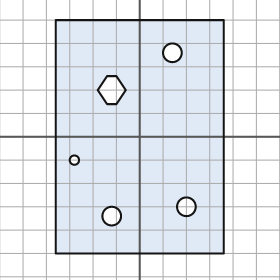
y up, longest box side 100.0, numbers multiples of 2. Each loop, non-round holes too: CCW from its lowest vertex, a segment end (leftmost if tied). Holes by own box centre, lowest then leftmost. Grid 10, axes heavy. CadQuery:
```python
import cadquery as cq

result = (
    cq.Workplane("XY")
    .moveTo(-36.0, -50.0)
    .lineTo(36.0, -50.0)
    .lineTo(36.0, 50.0)
    .lineTo(-36.0, 50.0)
    .close()
    .moveTo(-12.0, -34.0)
    .circle(4.0)
    .moveTo(20.0, -30.0)
    .circle(4.0)
    .moveTo(-28.0, -10.0)
    .circle(2.0)
    .moveTo(-14.0, 14.0)
    .lineTo(-10.0, 14.0)
    .lineTo(-6.0, 20.0)
    .lineTo(-10.0, 26.0)
    .lineTo(-14.0, 26.0)
    .lineTo(-18.0, 20.0)
    .close()
    .moveTo(14.0, 36.0)
    .circle(4.0)
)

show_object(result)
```